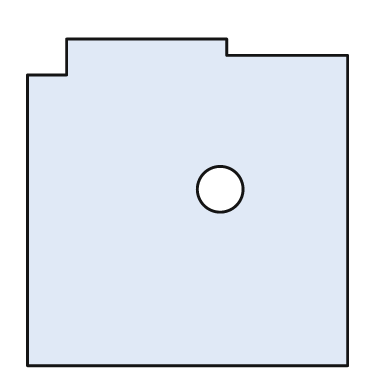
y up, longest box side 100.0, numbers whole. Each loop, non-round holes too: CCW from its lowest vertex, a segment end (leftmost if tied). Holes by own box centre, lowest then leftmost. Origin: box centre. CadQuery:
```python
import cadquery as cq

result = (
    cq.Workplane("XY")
    .moveTo(-49.0, -50.0)
    .lineTo(49.0, -50.0)
    .lineTo(49.0, 45.0)
    .lineTo(12.0, 45.0)
    .lineTo(12.0, 50.0)
    .lineTo(-37.0, 50.0)
    .lineTo(-37.0, 39.0)
    .lineTo(-49.0, 39.0)
    .close()
    .moveTo(10.0, 4.0)
    .circle(7.0)
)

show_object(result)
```